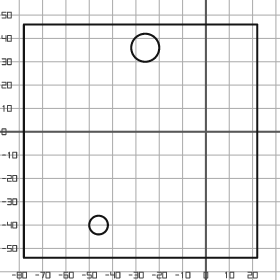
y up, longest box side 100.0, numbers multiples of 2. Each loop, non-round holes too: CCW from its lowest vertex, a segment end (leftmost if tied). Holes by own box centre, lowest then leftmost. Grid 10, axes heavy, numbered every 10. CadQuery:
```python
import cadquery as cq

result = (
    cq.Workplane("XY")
    .moveTo(-78.0, -54.0)
    .lineTo(22.0, -54.0)
    .lineTo(22.0, 46.0)
    .lineTo(-78.0, 46.0)
    .close()
    .moveTo(-46.0, -40.0)
    .circle(4.0)
    .moveTo(-26.0, 36.0)
    .circle(6.0)
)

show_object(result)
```